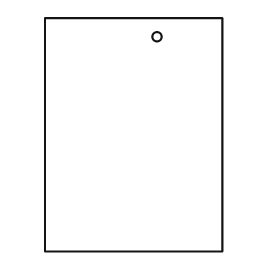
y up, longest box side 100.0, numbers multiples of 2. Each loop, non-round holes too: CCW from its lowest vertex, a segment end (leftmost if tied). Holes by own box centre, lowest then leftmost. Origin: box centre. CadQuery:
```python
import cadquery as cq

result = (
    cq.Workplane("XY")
    .moveTo(-38.0, -50.0)
    .lineTo(38.0, -50.0)
    .lineTo(38.0, 50.0)
    .lineTo(-38.0, 50.0)
    .close()
    .moveTo(10.0, 42.0)
    .circle(2.0)
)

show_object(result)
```